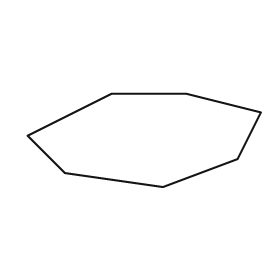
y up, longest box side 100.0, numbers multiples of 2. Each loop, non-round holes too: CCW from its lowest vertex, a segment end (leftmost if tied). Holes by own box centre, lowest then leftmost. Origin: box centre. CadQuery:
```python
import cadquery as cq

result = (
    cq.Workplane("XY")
    .moveTo(8.0, -20.0)
    .lineTo(40.0, -8.0)
    .lineTo(50.0, 12.0)
    .lineTo(18.0, 20.0)
    .lineTo(-14.0, 20.0)
    .lineTo(-50.0, 2.0)
    .lineTo(-34.0, -14.0)
    .close()
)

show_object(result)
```